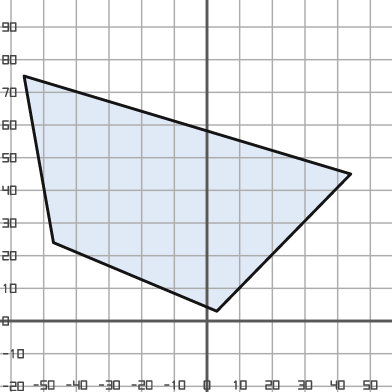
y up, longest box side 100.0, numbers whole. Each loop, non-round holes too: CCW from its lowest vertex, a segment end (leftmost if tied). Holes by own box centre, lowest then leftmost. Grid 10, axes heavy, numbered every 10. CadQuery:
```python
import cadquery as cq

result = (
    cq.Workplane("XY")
    .moveTo(3.0, 3.0)
    .lineTo(44.0, 45.0)
    .lineTo(-56.0, 75.0)
    .lineTo(-47.0, 24.0)
    .close()
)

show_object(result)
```